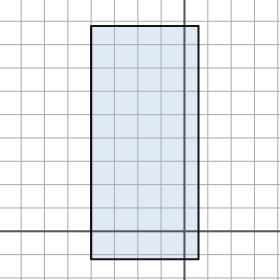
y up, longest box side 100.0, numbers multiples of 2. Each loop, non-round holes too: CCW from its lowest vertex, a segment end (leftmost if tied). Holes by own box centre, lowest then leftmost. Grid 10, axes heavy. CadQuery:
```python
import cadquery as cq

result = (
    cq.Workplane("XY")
    .moveTo(-40.0, -12.0)
    .lineTo(6.0, -12.0)
    .lineTo(6.0, 88.0)
    .lineTo(-40.0, 88.0)
    .close()
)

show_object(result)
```